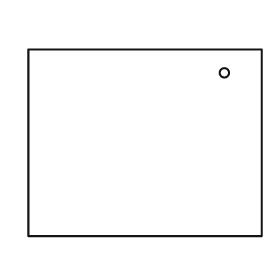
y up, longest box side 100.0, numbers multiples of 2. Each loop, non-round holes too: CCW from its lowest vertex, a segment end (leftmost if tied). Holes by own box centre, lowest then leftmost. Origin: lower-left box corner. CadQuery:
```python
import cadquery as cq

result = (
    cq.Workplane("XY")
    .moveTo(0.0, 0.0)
    .lineTo(100.0, 0.0)
    .lineTo(100.0, 80.0)
    .lineTo(0.0, 80.0)
    .close()
    .moveTo(84.0, 70.0)
    .circle(2.0)
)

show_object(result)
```